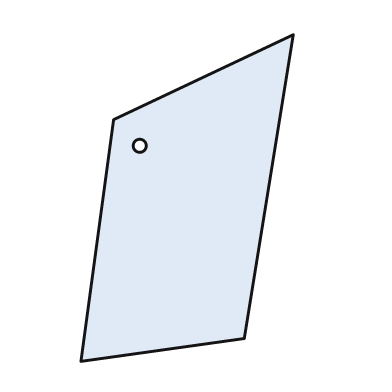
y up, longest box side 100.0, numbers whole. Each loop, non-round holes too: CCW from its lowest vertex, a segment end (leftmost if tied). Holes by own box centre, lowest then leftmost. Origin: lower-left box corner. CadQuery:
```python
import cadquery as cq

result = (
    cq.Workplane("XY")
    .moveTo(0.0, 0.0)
    .lineTo(50.0, 7.0)
    .lineTo(65.0, 100.0)
    .lineTo(10.0, 74.0)
    .close()
    .moveTo(18.0, 66.0)
    .circle(2.0)
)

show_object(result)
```